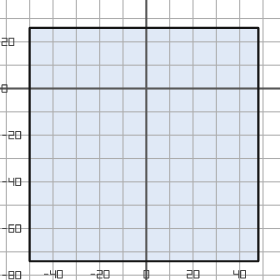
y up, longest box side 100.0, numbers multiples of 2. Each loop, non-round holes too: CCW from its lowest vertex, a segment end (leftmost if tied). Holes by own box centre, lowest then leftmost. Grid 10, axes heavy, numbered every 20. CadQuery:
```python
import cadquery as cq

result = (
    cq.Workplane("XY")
    .moveTo(-50.0, -74.0)
    .lineTo(48.0, -74.0)
    .lineTo(48.0, 26.0)
    .lineTo(-50.0, 26.0)
    .close()
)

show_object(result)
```